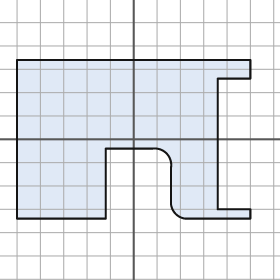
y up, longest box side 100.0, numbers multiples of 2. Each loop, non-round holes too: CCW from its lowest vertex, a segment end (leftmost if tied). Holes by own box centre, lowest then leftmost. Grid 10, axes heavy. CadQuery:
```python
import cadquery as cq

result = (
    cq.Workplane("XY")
    .moveTo(-50.0, -34.0)
    .lineTo(-12.0, -34.0)
    .lineTo(-12.0, -4.0)
    .lineTo(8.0, -4.0)
    .threePointArc((14.0, -6.0), (16.0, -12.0))
    .lineTo(16.0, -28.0)
    .threePointArc((18.0, -32.0), (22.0, -34.0))
    .lineTo(50.0, -34.0)
    .lineTo(50.0, -30.0)
    .lineTo(36.0, -30.0)
    .lineTo(36.0, 26.0)
    .lineTo(50.0, 26.0)
    .lineTo(50.0, 34.0)
    .lineTo(-50.0, 34.0)
    .close()
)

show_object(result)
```